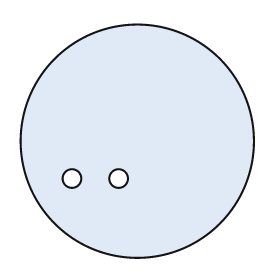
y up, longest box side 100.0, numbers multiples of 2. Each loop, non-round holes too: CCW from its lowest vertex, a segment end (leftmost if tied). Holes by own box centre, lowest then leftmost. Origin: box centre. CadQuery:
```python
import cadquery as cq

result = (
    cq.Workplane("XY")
    .moveTo(0.0, 0.0)
    .circle(50.0)
    .moveTo(-28.0, -16.0)
    .circle(4.0)
    .moveTo(-8.0, -16.0)
    .circle(4.0)
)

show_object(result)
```